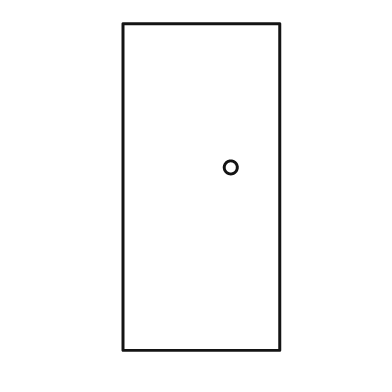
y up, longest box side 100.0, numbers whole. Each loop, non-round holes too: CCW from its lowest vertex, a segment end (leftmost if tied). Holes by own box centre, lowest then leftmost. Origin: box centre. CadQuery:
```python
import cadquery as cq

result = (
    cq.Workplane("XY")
    .moveTo(-24.0, -50.0)
    .lineTo(24.0, -50.0)
    .lineTo(24.0, 50.0)
    .lineTo(-24.0, 50.0)
    .close()
    .moveTo(9.0, 6.0)
    .circle(2.0)
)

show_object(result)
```